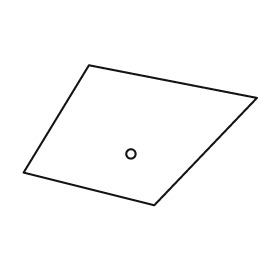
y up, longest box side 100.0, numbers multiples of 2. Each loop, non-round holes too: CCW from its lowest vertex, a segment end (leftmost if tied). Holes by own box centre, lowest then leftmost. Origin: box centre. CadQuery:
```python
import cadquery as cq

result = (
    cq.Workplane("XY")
    .moveTo(6.0, -30.0)
    .lineTo(50.0, 16.0)
    .lineTo(-22.0, 30.0)
    .lineTo(-50.0, -16.0)
    .close()
    .moveTo(-4.0, -8.0)
    .circle(2.0)
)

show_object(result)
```